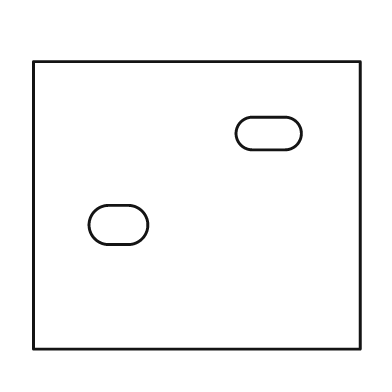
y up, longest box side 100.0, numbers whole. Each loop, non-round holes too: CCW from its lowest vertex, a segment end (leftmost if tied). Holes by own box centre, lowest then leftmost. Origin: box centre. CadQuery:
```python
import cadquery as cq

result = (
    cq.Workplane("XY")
    .moveTo(-50.0, -44.0)
    .lineTo(50.0, -44.0)
    .lineTo(50.0, 44.0)
    .lineTo(-50.0, 44.0)
    .close()
    .moveTo(-27.0, -12.0)
    .lineTo(-21.0, -12.0)
    .threePointArc((-15.0, -6.0), (-21.0, 0.0))
    .lineTo(-27.0, 0.0)
    .threePointArc((-33.0, -6.0), (-27.0, -12.0))
    .close()
    .moveTo(17.0, 17.0)
    .lineTo(27.0, 17.0)
    .threePointArc((32.0, 22.0), (27.0, 27.0))
    .lineTo(17.0, 27.0)
    .threePointArc((12.0, 22.0), (17.0, 17.0))
    .close()
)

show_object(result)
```